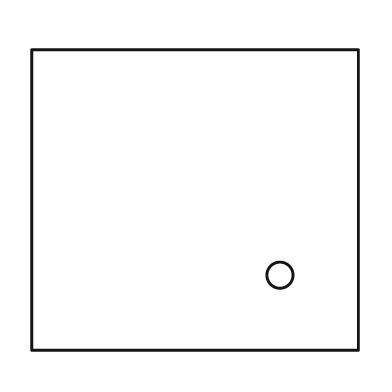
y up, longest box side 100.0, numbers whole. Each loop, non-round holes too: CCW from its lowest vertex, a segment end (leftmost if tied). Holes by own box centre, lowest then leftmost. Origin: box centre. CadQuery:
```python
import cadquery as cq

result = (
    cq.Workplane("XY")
    .moveTo(-50.0, -46.0)
    .lineTo(50.0, -46.0)
    .lineTo(50.0, 46.0)
    .lineTo(-50.0, 46.0)
    .close()
    .moveTo(26.0, -23.0)
    .circle(4.0)
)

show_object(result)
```